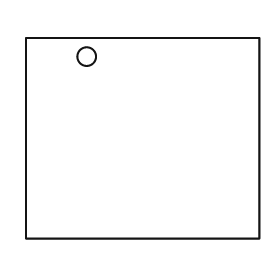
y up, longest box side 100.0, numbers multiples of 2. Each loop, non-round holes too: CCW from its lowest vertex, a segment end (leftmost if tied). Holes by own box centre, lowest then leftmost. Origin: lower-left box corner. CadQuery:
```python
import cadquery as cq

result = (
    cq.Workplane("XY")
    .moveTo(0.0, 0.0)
    .lineTo(100.0, 0.0)
    .lineTo(100.0, 86.0)
    .lineTo(0.0, 86.0)
    .close()
    .moveTo(26.0, 78.0)
    .circle(4.0)
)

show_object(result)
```